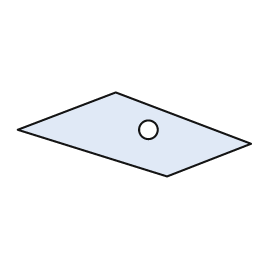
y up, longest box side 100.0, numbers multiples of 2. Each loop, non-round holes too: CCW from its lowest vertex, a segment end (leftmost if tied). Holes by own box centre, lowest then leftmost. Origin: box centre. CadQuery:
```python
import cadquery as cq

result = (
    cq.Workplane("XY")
    .moveTo(14.0, -18.0)
    .lineTo(50.0, -4.0)
    .lineTo(-8.0, 18.0)
    .lineTo(-50.0, 2.0)
    .close()
    .moveTo(6.0, 2.0)
    .circle(4.0)
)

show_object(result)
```